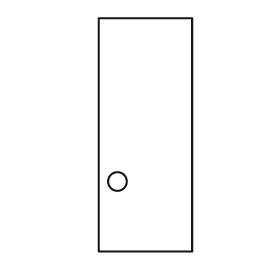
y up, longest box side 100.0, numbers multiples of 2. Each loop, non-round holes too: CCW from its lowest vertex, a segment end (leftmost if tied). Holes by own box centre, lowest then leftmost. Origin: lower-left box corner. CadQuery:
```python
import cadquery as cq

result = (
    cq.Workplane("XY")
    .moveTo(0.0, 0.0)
    .lineTo(40.0, 0.0)
    .lineTo(40.0, 100.0)
    .lineTo(0.0, 100.0)
    .close()
    .moveTo(8.0, 30.0)
    .circle(4.0)
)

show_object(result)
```